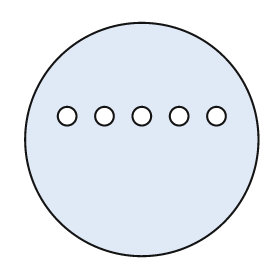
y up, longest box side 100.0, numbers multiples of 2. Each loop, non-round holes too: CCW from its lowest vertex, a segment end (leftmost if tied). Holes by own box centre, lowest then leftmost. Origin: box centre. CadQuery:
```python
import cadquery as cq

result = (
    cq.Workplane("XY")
    .moveTo(0.0, 0.0)
    .circle(50.0)
    .moveTo(-32.0, 10.0)
    .circle(4.0)
    .moveTo(-16.0, 10.0)
    .circle(4.0)
    .moveTo(0.0, 10.0)
    .circle(4.0)
    .moveTo(16.0, 10.0)
    .circle(4.0)
    .moveTo(32.0, 10.0)
    .circle(4.0)
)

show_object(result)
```